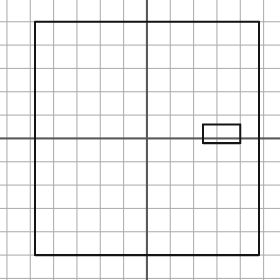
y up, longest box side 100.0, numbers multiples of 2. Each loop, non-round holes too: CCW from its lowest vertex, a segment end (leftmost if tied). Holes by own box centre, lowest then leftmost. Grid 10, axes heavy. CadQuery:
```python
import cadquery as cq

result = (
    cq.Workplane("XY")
    .moveTo(-48.0, -50.0)
    .lineTo(48.0, -50.0)
    .lineTo(48.0, 50.0)
    .lineTo(-48.0, 50.0)
    .close()
    .moveTo(24.0, -2.0)
    .lineTo(40.0, -2.0)
    .lineTo(40.0, 6.0)
    .lineTo(24.0, 6.0)
    .close()
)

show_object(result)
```